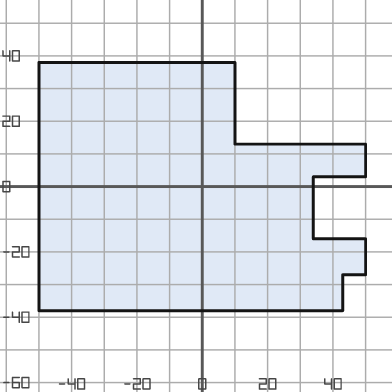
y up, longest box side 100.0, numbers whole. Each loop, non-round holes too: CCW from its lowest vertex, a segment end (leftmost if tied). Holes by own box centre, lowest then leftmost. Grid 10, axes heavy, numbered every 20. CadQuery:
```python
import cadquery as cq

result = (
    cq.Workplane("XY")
    .moveTo(-50.0, -38.0)
    .lineTo(43.0, -38.0)
    .lineTo(43.0, -27.0)
    .lineTo(50.0, -27.0)
    .lineTo(50.0, -16.0)
    .lineTo(34.0, -16.0)
    .lineTo(34.0, 3.0)
    .lineTo(50.0, 3.0)
    .lineTo(50.0, 13.0)
    .lineTo(10.0, 13.0)
    .lineTo(10.0, 38.0)
    .lineTo(-50.0, 38.0)
    .close()
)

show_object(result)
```